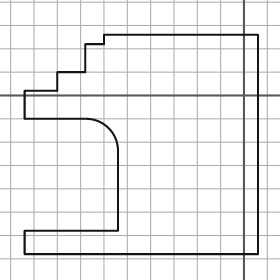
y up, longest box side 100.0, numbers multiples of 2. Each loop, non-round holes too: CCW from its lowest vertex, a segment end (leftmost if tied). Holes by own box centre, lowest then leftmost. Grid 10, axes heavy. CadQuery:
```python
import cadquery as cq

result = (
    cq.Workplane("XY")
    .moveTo(-94.0, -68.0)
    .lineTo(6.0, -68.0)
    .lineTo(6.0, 26.0)
    .lineTo(-60.0, 26.0)
    .lineTo(-60.0, 22.0)
    .lineTo(-68.0, 22.0)
    .lineTo(-68.0, 10.0)
    .lineTo(-80.0, 10.0)
    .lineTo(-80.0, 2.0)
    .lineTo(-94.0, 2.0)
    .lineTo(-94.0, -10.0)
    .lineTo(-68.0, -10.0)
    .threePointArc((-58.0, -14.0), (-54.0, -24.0))
    .lineTo(-54.0, -58.0)
    .lineTo(-94.0, -58.0)
    .close()
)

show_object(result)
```